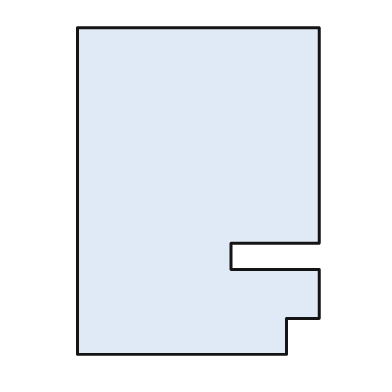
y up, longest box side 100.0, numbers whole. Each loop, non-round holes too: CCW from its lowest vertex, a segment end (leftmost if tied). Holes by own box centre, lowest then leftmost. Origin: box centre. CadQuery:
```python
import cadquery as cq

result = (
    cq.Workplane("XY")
    .moveTo(-37.0, -50.0)
    .lineTo(27.0, -50.0)
    .lineTo(27.0, -39.0)
    .lineTo(37.0, -39.0)
    .lineTo(37.0, -24.0)
    .lineTo(10.0, -24.0)
    .lineTo(10.0, -16.0)
    .lineTo(37.0, -16.0)
    .lineTo(37.0, 50.0)
    .lineTo(-37.0, 50.0)
    .close()
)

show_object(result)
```